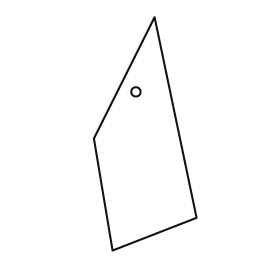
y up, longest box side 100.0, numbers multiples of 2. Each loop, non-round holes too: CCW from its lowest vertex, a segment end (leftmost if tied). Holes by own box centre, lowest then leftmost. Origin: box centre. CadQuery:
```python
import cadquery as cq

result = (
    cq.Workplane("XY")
    .moveTo(-14.0, -50.0)
    .lineTo(22.0, -36.0)
    .lineTo(4.0, 50.0)
    .lineTo(-22.0, -2.0)
    .close()
    .moveTo(-4.0, 18.0)
    .circle(2.0)
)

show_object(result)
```